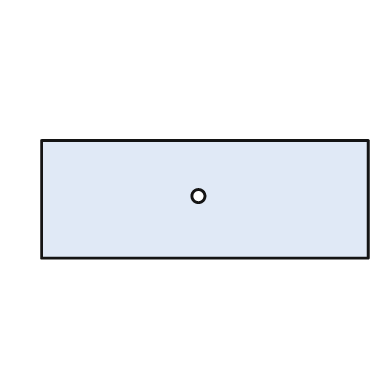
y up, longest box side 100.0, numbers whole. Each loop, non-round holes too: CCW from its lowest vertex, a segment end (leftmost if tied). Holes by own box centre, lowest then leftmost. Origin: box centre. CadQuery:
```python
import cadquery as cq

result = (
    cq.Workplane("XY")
    .moveTo(-50.0, -18.0)
    .lineTo(50.0, -18.0)
    .lineTo(50.0, 18.0)
    .lineTo(-50.0, 18.0)
    .close()
    .moveTo(-2.0, 1.0)
    .circle(2.0)
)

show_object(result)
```